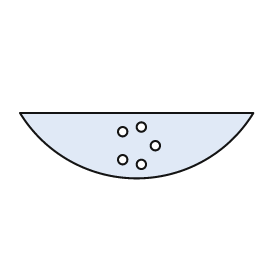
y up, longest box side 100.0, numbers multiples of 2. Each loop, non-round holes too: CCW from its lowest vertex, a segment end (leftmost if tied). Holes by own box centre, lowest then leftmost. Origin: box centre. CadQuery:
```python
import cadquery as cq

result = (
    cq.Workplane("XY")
    .moveTo(-50.0, 14.0)
    .threePointArc((0.0, -14.0), (50.0, 14.0))
    .close()
    .moveTo(2.0, -8.0)
    .circle(2.0)
    .moveTo(-6.0, -6.0)
    .circle(2.0)
    .moveTo(8.0, 0.0)
    .circle(2.0)
    .moveTo(-6.0, 6.0)
    .circle(2.0)
    .moveTo(2.0, 8.0)
    .circle(2.0)
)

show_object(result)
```